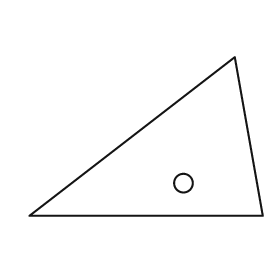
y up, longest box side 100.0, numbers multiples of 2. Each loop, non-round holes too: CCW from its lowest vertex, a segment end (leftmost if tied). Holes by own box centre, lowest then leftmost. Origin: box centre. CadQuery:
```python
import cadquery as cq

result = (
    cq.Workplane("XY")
    .moveTo(-50.0, -34.0)
    .lineTo(50.0, -34.0)
    .lineTo(38.0, 34.0)
    .close()
    .moveTo(16.0, -20.0)
    .circle(4.0)
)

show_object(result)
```